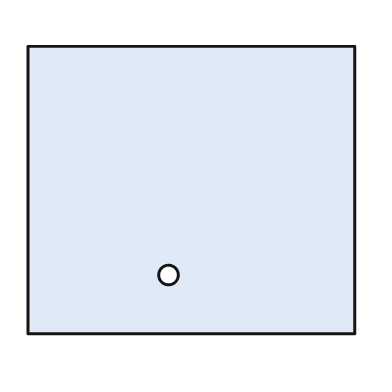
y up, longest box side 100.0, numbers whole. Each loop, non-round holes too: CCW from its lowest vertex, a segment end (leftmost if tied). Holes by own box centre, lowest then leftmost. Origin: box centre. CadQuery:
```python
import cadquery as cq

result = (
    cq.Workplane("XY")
    .moveTo(-50.0, -44.0)
    .lineTo(50.0, -44.0)
    .lineTo(50.0, 44.0)
    .lineTo(-50.0, 44.0)
    .close()
    .moveTo(-7.0, -26.0)
    .circle(3.0)
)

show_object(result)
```